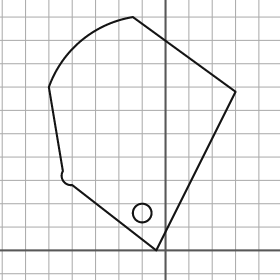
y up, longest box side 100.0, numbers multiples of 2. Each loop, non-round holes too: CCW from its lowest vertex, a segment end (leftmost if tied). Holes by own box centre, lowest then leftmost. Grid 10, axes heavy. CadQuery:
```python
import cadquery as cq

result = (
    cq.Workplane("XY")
    .moveTo(-4.0, 0.0)
    .lineTo(30.0, 68.0)
    .lineTo(-14.0, 100.0)
    .threePointArc((-36.0, 90.0), (-50.0, 70.0))
    .lineTo(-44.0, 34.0)
    .threePointArc((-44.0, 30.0), (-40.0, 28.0))
    .close()
    .moveTo(-10.0, 16.0)
    .circle(4.0)
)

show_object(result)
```